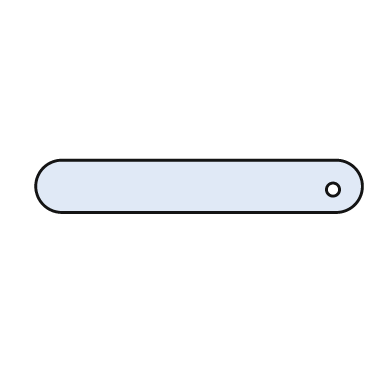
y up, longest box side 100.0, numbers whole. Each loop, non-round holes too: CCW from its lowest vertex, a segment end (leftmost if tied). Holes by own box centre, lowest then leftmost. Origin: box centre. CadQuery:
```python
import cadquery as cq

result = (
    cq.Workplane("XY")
    .moveTo(-42.0, -8.0)
    .lineTo(42.0, -8.0)
    .threePointArc((50.0, 0.0), (42.0, 8.0))
    .lineTo(-42.0, 8.0)
    .threePointArc((-50.0, 0.0), (-42.0, -8.0))
    .close()
    .moveTo(41.0, -1.0)
    .circle(2.0)
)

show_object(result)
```